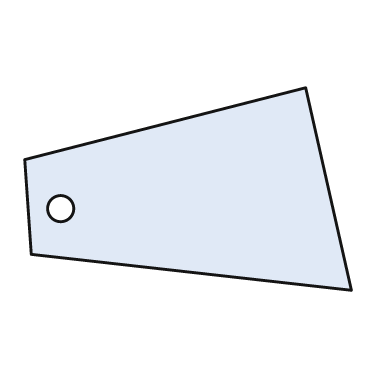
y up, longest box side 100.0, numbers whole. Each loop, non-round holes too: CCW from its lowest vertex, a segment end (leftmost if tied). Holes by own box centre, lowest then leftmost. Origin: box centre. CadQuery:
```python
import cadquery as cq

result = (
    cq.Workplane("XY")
    .moveTo(50.0, -31.0)
    .lineTo(36.0, 31.0)
    .lineTo(-50.0, 9.0)
    .lineTo(-48.0, -20.0)
    .close()
    .moveTo(-39.0, -6.0)
    .circle(4.0)
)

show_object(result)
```